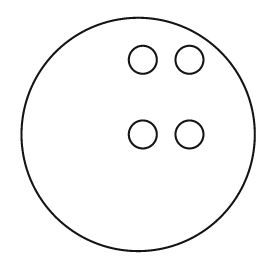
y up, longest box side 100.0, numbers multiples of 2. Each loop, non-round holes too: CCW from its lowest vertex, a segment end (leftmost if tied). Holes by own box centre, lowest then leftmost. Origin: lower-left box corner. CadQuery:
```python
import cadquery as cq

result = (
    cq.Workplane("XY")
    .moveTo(50.0, 50.0)
    .circle(50.0)
    .moveTo(52.0, 50.0)
    .circle(6.0)
    .moveTo(72.0, 50.0)
    .circle(6.0)
    .moveTo(52.0, 82.0)
    .circle(6.0)
    .moveTo(72.0, 82.0)
    .circle(6.0)
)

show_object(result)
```